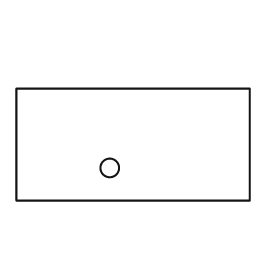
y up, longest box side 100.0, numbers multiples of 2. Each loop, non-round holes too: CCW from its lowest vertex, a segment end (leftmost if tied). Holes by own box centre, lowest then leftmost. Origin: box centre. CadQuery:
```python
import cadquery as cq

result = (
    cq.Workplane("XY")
    .moveTo(-50.0, -24.0)
    .lineTo(50.0, -24.0)
    .lineTo(50.0, 24.0)
    .lineTo(-50.0, 24.0)
    .close()
    .moveTo(-10.0, -10.0)
    .circle(4.0)
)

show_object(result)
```